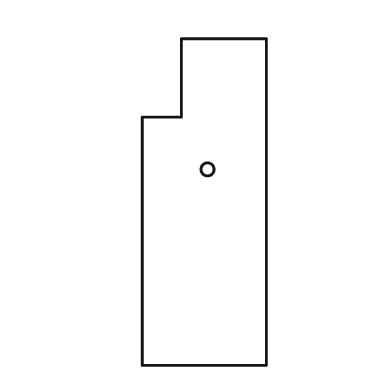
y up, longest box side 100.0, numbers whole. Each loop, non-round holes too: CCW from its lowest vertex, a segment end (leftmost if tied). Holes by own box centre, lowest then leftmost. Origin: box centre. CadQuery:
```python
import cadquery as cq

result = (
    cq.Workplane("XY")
    .moveTo(-19.0, -50.0)
    .lineTo(19.0, -50.0)
    .lineTo(19.0, 50.0)
    .lineTo(-7.0, 50.0)
    .lineTo(-7.0, 26.0)
    .lineTo(-19.0, 26.0)
    .close()
    .moveTo(1.0, 10.0)
    .circle(2.0)
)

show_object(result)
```